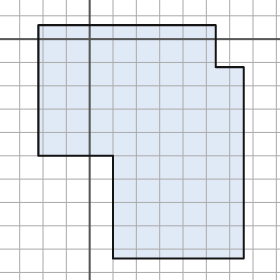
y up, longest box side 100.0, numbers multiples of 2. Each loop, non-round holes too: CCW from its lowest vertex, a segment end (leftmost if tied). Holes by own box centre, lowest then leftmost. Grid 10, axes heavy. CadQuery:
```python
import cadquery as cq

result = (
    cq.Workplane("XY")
    .moveTo(10.0, -94.0)
    .lineTo(66.0, -94.0)
    .lineTo(66.0, -12.0)
    .lineTo(54.0, -12.0)
    .lineTo(54.0, 6.0)
    .lineTo(-22.0, 6.0)
    .lineTo(-22.0, -50.0)
    .lineTo(10.0, -50.0)
    .close()
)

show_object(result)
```